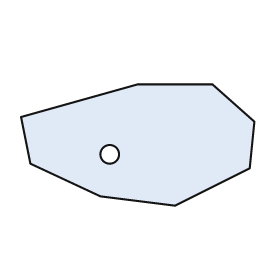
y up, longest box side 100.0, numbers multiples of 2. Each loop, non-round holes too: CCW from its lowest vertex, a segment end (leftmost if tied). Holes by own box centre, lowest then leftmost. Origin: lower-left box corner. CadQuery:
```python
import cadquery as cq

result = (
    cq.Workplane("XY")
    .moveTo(66.0, 0.0)
    .lineTo(98.0, 16.0)
    .lineTo(100.0, 36.0)
    .lineTo(82.0, 52.0)
    .lineTo(50.0, 52.0)
    .lineTo(0.0, 38.0)
    .lineTo(4.0, 18.0)
    .lineTo(34.0, 4.0)
    .close()
    .moveTo(38.0, 22.0)
    .circle(4.0)
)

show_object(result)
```